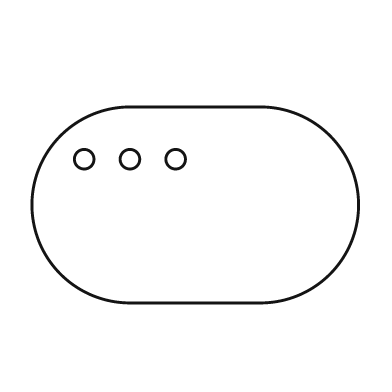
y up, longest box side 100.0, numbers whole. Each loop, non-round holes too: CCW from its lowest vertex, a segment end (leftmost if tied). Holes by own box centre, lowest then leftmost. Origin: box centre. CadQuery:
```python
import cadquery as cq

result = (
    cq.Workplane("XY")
    .moveTo(-20.0, -30.0)
    .lineTo(20.0, -30.0)
    .threePointArc((50.0, 0.0), (20.0, 30.0))
    .lineTo(-20.0, 30.0)
    .threePointArc((-50.0, 0.0), (-20.0, -30.0))
    .close()
    .moveTo(-34.0, 14.0)
    .circle(3.0)
    .moveTo(-20.0, 14.0)
    .circle(3.0)
    .moveTo(-6.0, 14.0)
    .circle(3.0)
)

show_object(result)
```